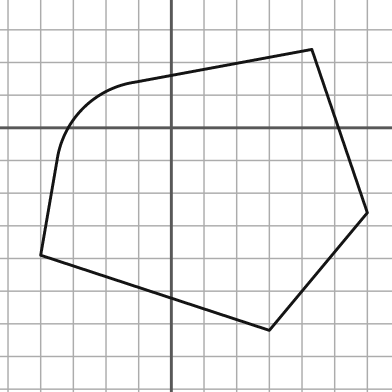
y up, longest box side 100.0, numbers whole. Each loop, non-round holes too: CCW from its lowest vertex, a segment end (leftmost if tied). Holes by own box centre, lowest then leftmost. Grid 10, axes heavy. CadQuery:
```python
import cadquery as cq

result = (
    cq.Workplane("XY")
    .moveTo(30.0, -62.0)
    .lineTo(60.0, -26.0)
    .lineTo(43.0, 24.0)
    .lineTo(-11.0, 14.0)
    .threePointArc((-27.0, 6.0), (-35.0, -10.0))
    .lineTo(-40.0, -39.0)
    .close()
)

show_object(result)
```